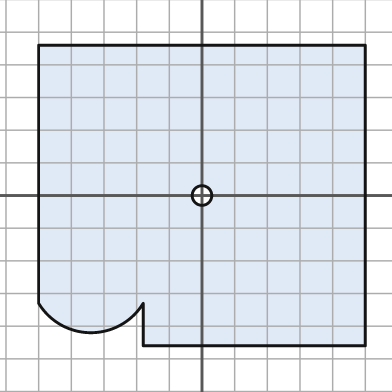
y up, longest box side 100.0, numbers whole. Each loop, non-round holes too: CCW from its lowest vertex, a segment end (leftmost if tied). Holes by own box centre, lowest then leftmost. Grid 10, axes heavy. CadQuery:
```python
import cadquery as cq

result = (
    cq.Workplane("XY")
    .moveTo(-18.0, -46.0)
    .lineTo(50.0, -46.0)
    .lineTo(50.0, 46.0)
    .lineTo(-50.0, 46.0)
    .lineTo(-50.0, -33.0)
    .threePointArc((-34.0, -42.0), (-18.0, -33.0))
    .close()
    .moveTo(0.0, 0.0)
    .circle(3.0)
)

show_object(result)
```